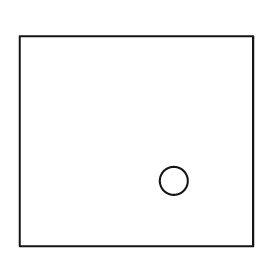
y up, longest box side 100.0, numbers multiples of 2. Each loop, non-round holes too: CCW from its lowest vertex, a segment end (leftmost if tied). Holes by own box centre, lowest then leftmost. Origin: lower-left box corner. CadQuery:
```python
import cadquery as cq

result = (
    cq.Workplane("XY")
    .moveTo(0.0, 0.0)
    .lineTo(100.0, 0.0)
    .lineTo(100.0, 90.0)
    .lineTo(0.0, 90.0)
    .close()
    .moveTo(66.0, 28.0)
    .circle(6.0)
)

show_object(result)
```